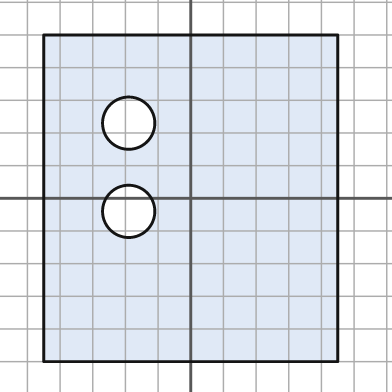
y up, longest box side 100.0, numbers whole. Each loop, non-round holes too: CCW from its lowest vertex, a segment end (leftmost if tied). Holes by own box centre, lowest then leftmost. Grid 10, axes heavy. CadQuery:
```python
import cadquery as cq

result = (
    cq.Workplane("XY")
    .moveTo(-45.0, -50.0)
    .lineTo(45.0, -50.0)
    .lineTo(45.0, 50.0)
    .lineTo(-45.0, 50.0)
    .close()
    .moveTo(-19.0, -4.0)
    .circle(8.0)
    .moveTo(-19.0, 23.0)
    .circle(8.0)
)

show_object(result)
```